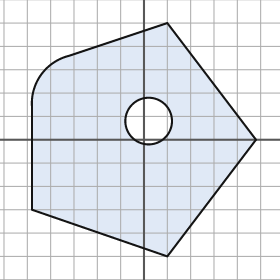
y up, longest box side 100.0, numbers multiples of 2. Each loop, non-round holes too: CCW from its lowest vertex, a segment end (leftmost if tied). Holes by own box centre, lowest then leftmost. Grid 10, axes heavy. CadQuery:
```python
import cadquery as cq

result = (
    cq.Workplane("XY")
    .moveTo(10.0, -50.0)
    .lineTo(48.0, 0.0)
    .lineTo(10.0, 50.0)
    .lineTo(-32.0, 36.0)
    .threePointArc((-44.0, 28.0), (-48.0, 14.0))
    .lineTo(-48.0, -30.0)
    .close()
    .moveTo(2.0, 8.0)
    .circle(10.0)
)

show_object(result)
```